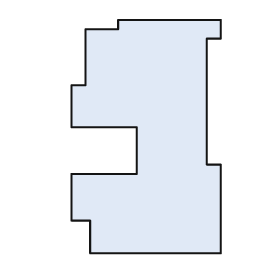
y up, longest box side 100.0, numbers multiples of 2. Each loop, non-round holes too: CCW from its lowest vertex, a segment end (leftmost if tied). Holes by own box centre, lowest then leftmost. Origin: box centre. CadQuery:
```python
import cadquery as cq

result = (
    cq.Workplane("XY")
    .moveTo(-24.0, -50.0)
    .lineTo(32.0, -50.0)
    .lineTo(32.0, -12.0)
    .lineTo(26.0, -12.0)
    .lineTo(26.0, 42.0)
    .lineTo(32.0, 42.0)
    .lineTo(32.0, 50.0)
    .lineTo(-12.0, 50.0)
    .lineTo(-12.0, 46.0)
    .lineTo(-26.0, 46.0)
    .lineTo(-26.0, 22.0)
    .lineTo(-32.0, 22.0)
    .lineTo(-32.0, 4.0)
    .lineTo(-4.0, 4.0)
    .lineTo(-4.0, -16.0)
    .lineTo(-32.0, -16.0)
    .lineTo(-32.0, -36.0)
    .lineTo(-24.0, -36.0)
    .close()
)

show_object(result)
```